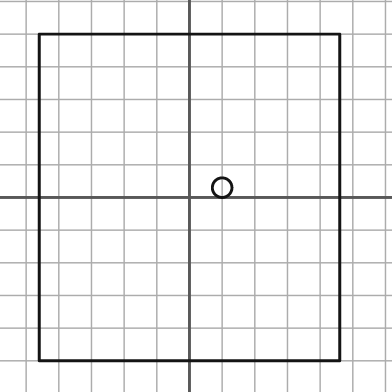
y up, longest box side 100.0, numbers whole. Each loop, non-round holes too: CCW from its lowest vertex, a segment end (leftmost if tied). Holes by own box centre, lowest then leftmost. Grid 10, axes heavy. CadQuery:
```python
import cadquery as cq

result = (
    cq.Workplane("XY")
    .moveTo(-46.0, -50.0)
    .lineTo(46.0, -50.0)
    .lineTo(46.0, 50.0)
    .lineTo(-46.0, 50.0)
    .close()
    .moveTo(10.0, 3.0)
    .circle(3.0)
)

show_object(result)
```